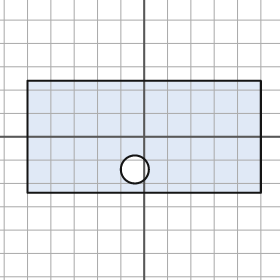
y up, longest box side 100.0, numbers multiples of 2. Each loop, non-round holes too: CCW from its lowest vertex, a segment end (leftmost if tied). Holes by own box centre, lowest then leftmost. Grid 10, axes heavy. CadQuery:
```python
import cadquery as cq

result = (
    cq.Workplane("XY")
    .moveTo(-50.0, -24.0)
    .lineTo(50.0, -24.0)
    .lineTo(50.0, 24.0)
    .lineTo(-50.0, 24.0)
    .close()
    .moveTo(-4.0, -14.0)
    .circle(6.0)
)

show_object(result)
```